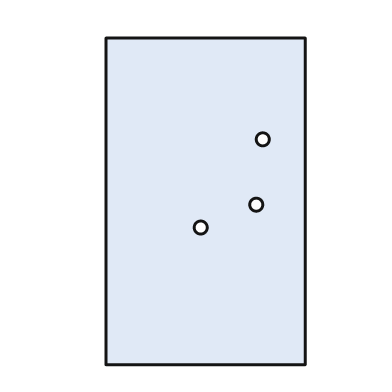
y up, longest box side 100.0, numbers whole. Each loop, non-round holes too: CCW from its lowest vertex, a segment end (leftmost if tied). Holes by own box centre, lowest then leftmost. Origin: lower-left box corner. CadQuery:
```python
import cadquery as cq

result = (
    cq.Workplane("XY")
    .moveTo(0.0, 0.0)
    .lineTo(61.0, 0.0)
    .lineTo(61.0, 100.0)
    .lineTo(0.0, 100.0)
    .close()
    .moveTo(29.0, 42.0)
    .circle(2.0)
    .moveTo(46.0, 49.0)
    .circle(2.0)
    .moveTo(48.0, 69.0)
    .circle(2.0)
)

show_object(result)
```